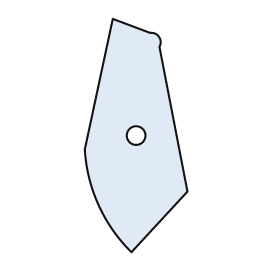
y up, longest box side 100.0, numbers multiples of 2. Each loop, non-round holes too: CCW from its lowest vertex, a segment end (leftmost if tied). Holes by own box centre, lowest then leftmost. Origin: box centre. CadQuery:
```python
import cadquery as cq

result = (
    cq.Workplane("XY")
    .moveTo(-2.0, -50.0)
    .lineTo(22.0, -24.0)
    .lineTo(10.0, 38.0)
    .threePointArc((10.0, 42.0), (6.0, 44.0))
    .lineTo(-10.0, 50.0)
    .lineTo(-22.0, -6.0)
    .threePointArc((-16.0, -30.0), (-2.0, -50.0))
    .close()
    .moveTo(0.0, 0.0)
    .circle(4.0)
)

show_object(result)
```